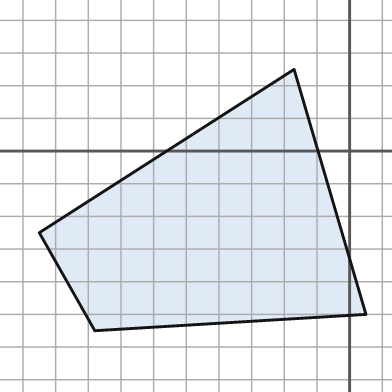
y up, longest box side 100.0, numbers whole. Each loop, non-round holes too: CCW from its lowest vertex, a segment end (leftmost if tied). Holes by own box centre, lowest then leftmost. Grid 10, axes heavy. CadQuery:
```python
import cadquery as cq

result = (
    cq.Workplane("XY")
    .moveTo(-78.0, -55.0)
    .lineTo(5.0, -50.0)
    .lineTo(-17.0, 25.0)
    .lineTo(-95.0, -25.0)
    .close()
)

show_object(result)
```